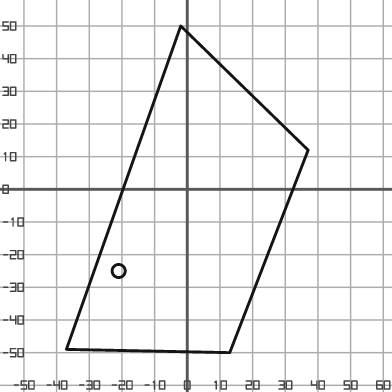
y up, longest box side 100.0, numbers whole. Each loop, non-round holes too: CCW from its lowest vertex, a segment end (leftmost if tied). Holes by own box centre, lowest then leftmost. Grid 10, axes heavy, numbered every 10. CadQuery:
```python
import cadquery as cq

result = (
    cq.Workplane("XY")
    .moveTo(13.0, -50.0)
    .lineTo(37.0, 12.0)
    .lineTo(-2.0, 50.0)
    .lineTo(-37.0, -49.0)
    .close()
    .moveTo(-21.0, -25.0)
    .circle(2.0)
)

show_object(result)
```